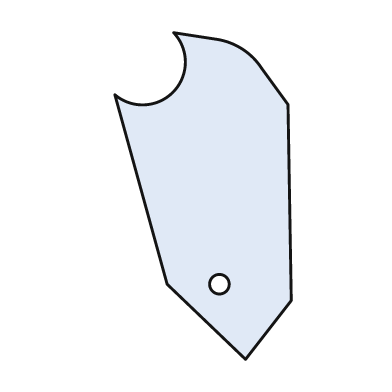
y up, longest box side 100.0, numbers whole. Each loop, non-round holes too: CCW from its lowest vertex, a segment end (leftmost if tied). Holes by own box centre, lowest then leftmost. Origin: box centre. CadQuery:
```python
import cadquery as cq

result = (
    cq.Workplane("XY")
    .moveTo(13.0, -50.0)
    .lineTo(27.0, -32.0)
    .lineTo(26.0, 28.0)
    .lineTo(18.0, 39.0)
    .threePointArc((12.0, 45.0), (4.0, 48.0))
    .lineTo(-9.0, 50.0)
    .threePointArc((-9.0, 32.0), (-27.0, 31.0))
    .lineTo(-11.0, -27.0)
    .close()
    .moveTo(5.0, -27.0)
    .circle(3.0)
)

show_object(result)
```